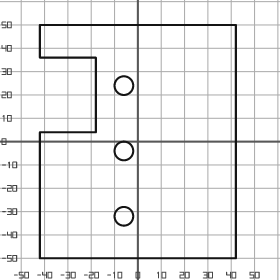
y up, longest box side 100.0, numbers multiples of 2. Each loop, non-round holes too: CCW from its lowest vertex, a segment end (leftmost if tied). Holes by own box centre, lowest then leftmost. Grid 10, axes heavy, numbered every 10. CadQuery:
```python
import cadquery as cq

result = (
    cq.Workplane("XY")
    .moveTo(-42.0, -50.0)
    .lineTo(42.0, -50.0)
    .lineTo(42.0, 50.0)
    .lineTo(-42.0, 50.0)
    .lineTo(-42.0, 36.0)
    .lineTo(-18.0, 36.0)
    .lineTo(-18.0, 4.0)
    .lineTo(-42.0, 4.0)
    .close()
    .moveTo(-6.0, -32.0)
    .circle(4.0)
    .moveTo(-6.0, -4.0)
    .circle(4.0)
    .moveTo(-6.0, 24.0)
    .circle(4.0)
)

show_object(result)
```